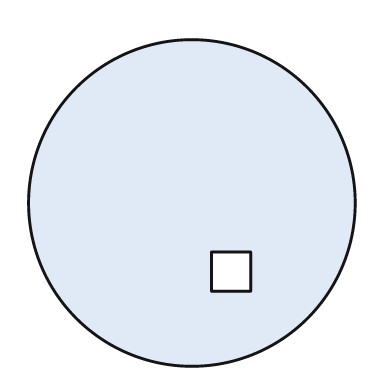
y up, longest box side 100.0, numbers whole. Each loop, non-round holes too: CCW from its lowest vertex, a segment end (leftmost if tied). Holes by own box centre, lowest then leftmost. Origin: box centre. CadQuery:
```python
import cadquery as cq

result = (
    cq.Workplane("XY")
    .moveTo(0.0, 0.0)
    .circle(50.0)
    .moveTo(6.0, -27.0)
    .lineTo(18.0, -27.0)
    .lineTo(18.0, -15.0)
    .lineTo(6.0, -15.0)
    .close()
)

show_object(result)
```